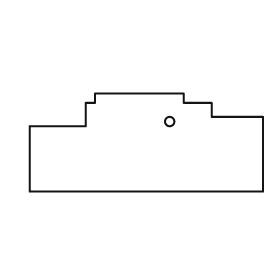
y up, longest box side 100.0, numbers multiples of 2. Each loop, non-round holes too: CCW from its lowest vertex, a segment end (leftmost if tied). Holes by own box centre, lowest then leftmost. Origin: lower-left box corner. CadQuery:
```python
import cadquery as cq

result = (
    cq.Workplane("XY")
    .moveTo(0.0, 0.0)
    .lineTo(100.0, 0.0)
    .lineTo(100.0, 32.0)
    .lineTo(78.0, 32.0)
    .lineTo(78.0, 38.0)
    .lineTo(66.0, 38.0)
    .lineTo(66.0, 42.0)
    .lineTo(28.0, 42.0)
    .lineTo(28.0, 38.0)
    .lineTo(24.0, 38.0)
    .lineTo(24.0, 28.0)
    .lineTo(0.0, 28.0)
    .close()
    .moveTo(60.0, 30.0)
    .circle(2.0)
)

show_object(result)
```